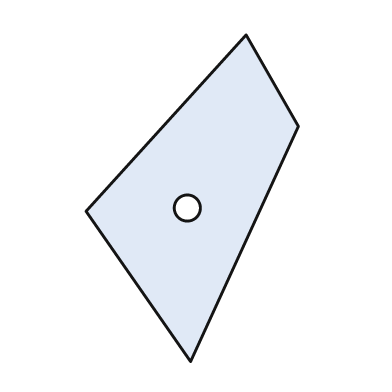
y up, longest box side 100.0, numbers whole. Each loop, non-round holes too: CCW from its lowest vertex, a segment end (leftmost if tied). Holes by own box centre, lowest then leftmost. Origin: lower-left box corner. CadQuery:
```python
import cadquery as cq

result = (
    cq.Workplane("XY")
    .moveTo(32.0, 0.0)
    .lineTo(65.0, 72.0)
    .lineTo(49.0, 100.0)
    .lineTo(0.0, 46.0)
    .close()
    .moveTo(31.0, 47.0)
    .circle(4.0)
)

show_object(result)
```